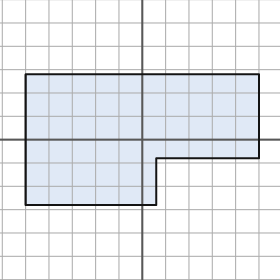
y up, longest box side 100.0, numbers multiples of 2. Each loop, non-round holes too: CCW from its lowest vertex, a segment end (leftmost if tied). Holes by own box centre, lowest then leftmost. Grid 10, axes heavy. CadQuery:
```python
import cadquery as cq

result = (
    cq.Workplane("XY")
    .moveTo(-50.0, -28.0)
    .lineTo(6.0, -28.0)
    .lineTo(6.0, -8.0)
    .lineTo(50.0, -8.0)
    .lineTo(50.0, 28.0)
    .lineTo(-50.0, 28.0)
    .close()
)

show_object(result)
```